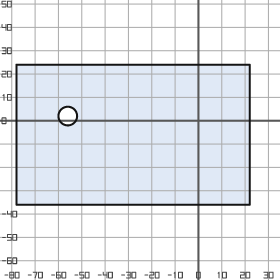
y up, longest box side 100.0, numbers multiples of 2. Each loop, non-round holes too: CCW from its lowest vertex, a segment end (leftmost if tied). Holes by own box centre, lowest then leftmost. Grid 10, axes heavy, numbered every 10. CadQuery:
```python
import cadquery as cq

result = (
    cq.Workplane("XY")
    .moveTo(-78.0, -36.0)
    .lineTo(22.0, -36.0)
    .lineTo(22.0, 24.0)
    .lineTo(-78.0, 24.0)
    .close()
    .moveTo(-56.0, 2.0)
    .circle(4.0)
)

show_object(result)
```